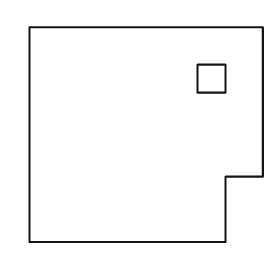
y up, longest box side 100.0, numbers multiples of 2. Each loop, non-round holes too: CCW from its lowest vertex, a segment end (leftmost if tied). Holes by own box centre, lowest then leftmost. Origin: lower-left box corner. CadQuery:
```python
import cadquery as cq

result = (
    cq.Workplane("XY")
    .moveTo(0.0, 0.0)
    .lineTo(84.0, 0.0)
    .lineTo(84.0, 28.0)
    .lineTo(100.0, 28.0)
    .lineTo(100.0, 92.0)
    .lineTo(0.0, 92.0)
    .close()
    .moveTo(72.0, 64.0)
    .lineTo(84.0, 64.0)
    .lineTo(84.0, 76.0)
    .lineTo(72.0, 76.0)
    .close()
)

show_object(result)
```